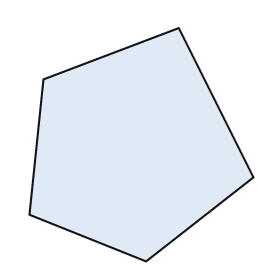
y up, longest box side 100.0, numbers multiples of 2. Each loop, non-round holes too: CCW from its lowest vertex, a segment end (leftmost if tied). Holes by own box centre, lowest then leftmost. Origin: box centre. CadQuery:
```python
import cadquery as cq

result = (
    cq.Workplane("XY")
    .moveTo(2.0, -50.0)
    .lineTo(48.0, -14.0)
    .lineTo(16.0, 50.0)
    .lineTo(-42.0, 28.0)
    .lineTo(-48.0, -30.0)
    .close()
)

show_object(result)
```